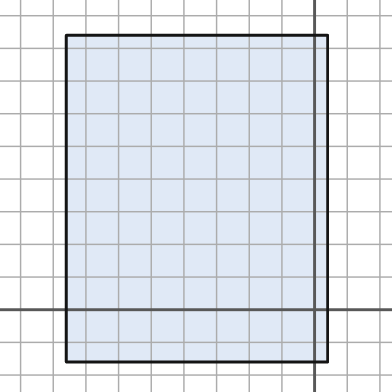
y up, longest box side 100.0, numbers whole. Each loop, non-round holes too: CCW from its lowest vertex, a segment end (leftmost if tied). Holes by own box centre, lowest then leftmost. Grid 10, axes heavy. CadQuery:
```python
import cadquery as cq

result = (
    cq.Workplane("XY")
    .moveTo(-76.0, -16.0)
    .lineTo(4.0, -16.0)
    .lineTo(4.0, 84.0)
    .lineTo(-76.0, 84.0)
    .close()
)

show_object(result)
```